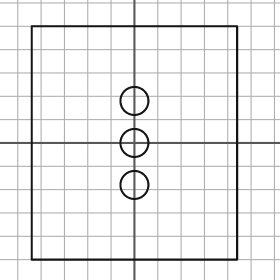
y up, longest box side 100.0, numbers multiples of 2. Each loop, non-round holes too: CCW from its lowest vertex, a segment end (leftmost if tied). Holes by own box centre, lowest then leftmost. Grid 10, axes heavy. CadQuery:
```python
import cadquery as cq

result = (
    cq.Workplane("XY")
    .moveTo(-44.0, -50.0)
    .lineTo(44.0, -50.0)
    .lineTo(44.0, 50.0)
    .lineTo(-44.0, 50.0)
    .close()
    .moveTo(0.0, -18.0)
    .circle(6.0)
    .moveTo(0.0, 0.0)
    .circle(6.0)
    .moveTo(0.0, 18.0)
    .circle(6.0)
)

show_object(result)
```